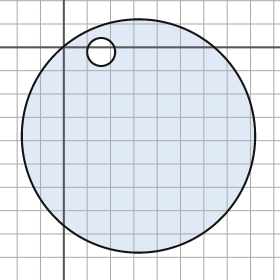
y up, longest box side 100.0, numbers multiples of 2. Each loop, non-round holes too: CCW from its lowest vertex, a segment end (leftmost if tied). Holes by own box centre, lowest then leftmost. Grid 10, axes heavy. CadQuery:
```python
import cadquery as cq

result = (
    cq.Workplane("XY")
    .moveTo(32.0, -38.0)
    .circle(50.0)
    .moveTo(16.0, -2.0)
    .circle(6.0)
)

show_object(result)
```